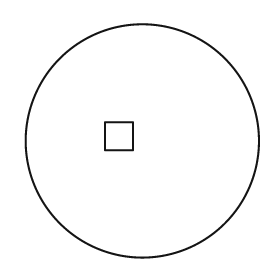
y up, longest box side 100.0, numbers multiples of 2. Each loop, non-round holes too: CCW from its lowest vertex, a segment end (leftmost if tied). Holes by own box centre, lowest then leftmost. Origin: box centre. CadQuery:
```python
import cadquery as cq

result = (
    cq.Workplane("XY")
    .moveTo(0.0, 0.0)
    .circle(50.0)
    .moveTo(-16.0, -4.0)
    .lineTo(-4.0, -4.0)
    .lineTo(-4.0, 8.0)
    .lineTo(-16.0, 8.0)
    .close()
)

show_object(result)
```